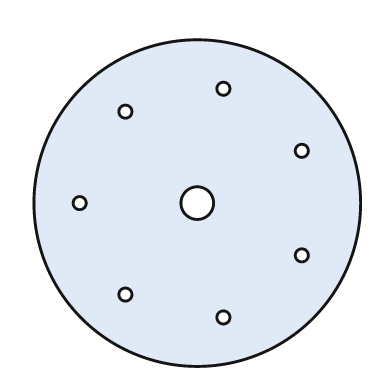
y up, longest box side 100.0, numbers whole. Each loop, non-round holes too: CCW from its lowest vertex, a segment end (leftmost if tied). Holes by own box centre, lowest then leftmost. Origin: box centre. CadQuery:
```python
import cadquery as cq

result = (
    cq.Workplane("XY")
    .moveTo(0.0, 0.0)
    .circle(50.0)
    .moveTo(8.0, -35.0)
    .circle(2.0)
    .moveTo(-22.0, -28.0)
    .circle(2.0)
    .moveTo(32.0, -16.0)
    .circle(2.0)
    .moveTo(-36.0, 0.0)
    .circle(2.0)
    .moveTo(0.0, 0.0)
    .circle(5.0)
    .moveTo(32.0, 16.0)
    .circle(2.0)
    .moveTo(-22.0, 28.0)
    .circle(2.0)
    .moveTo(8.0, 35.0)
    .circle(2.0)
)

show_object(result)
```